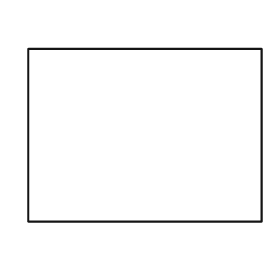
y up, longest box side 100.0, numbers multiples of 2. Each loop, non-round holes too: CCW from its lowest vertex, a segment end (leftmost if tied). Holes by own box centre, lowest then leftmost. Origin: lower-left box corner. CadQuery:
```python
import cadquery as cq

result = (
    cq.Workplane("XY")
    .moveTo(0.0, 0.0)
    .lineTo(100.0, 0.0)
    .lineTo(100.0, 74.0)
    .lineTo(0.0, 74.0)
    .close()
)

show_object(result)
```